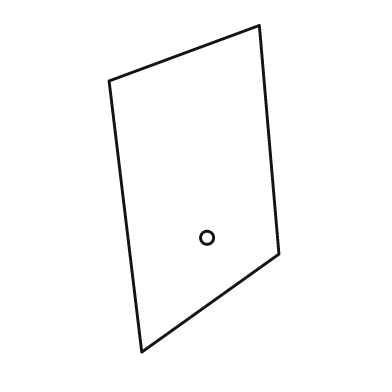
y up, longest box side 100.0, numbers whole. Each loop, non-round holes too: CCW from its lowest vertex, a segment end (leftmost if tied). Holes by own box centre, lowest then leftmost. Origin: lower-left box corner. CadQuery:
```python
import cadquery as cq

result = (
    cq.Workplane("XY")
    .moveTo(10.0, 0.0)
    .lineTo(52.0, 30.0)
    .lineTo(46.0, 100.0)
    .lineTo(0.0, 83.0)
    .close()
    .moveTo(30.0, 35.0)
    .circle(2.0)
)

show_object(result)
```